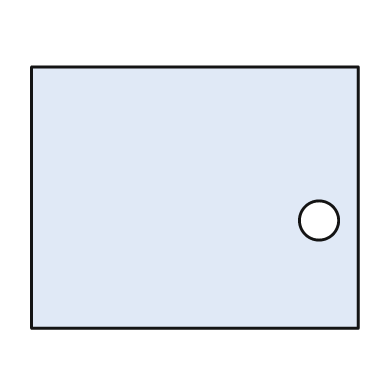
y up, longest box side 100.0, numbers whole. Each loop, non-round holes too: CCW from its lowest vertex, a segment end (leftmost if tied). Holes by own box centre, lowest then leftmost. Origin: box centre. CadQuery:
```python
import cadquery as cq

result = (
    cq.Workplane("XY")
    .moveTo(-50.0, -40.0)
    .lineTo(50.0, -40.0)
    .lineTo(50.0, 40.0)
    .lineTo(-50.0, 40.0)
    .close()
    .moveTo(38.0, -7.0)
    .circle(6.0)
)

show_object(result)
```